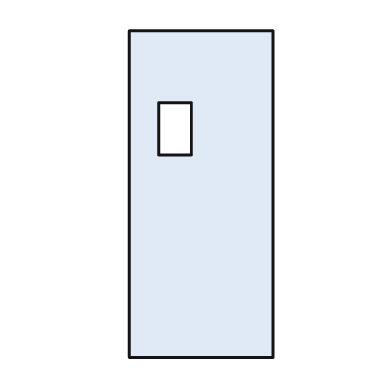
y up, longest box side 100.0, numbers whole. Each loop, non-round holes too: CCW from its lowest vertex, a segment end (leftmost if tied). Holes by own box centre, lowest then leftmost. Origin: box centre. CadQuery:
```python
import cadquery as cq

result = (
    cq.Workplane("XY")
    .moveTo(-22.0, -50.0)
    .lineTo(22.0, -50.0)
    .lineTo(22.0, 50.0)
    .lineTo(-22.0, 50.0)
    .close()
    .moveTo(-13.0, 12.0)
    .lineTo(-3.0, 12.0)
    .lineTo(-3.0, 28.0)
    .lineTo(-13.0, 28.0)
    .close()
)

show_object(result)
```